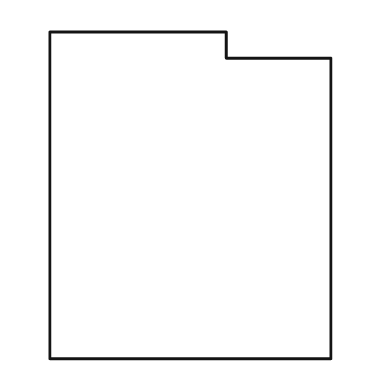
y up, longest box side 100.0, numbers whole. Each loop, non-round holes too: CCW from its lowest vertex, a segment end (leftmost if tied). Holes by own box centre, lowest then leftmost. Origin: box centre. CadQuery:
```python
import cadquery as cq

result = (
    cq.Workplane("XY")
    .moveTo(-43.0, -50.0)
    .lineTo(43.0, -50.0)
    .lineTo(43.0, 42.0)
    .lineTo(11.0, 42.0)
    .lineTo(11.0, 50.0)
    .lineTo(-43.0, 50.0)
    .close()
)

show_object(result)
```